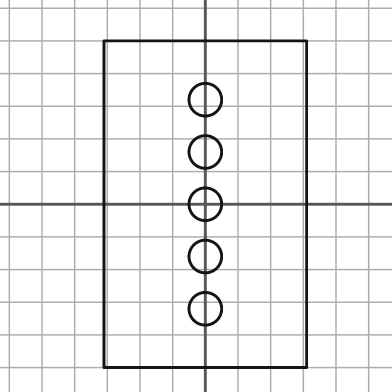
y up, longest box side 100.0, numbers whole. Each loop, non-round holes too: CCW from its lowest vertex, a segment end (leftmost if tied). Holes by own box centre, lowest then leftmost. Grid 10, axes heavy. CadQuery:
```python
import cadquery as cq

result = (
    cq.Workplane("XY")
    .moveTo(-31.0, -50.0)
    .lineTo(31.0, -50.0)
    .lineTo(31.0, 50.0)
    .lineTo(-31.0, 50.0)
    .close()
    .moveTo(0.0, -32.0)
    .circle(5.0)
    .moveTo(0.0, -16.0)
    .circle(5.0)
    .moveTo(0.0, 0.0)
    .circle(5.0)
    .moveTo(0.0, 16.0)
    .circle(5.0)
    .moveTo(0.0, 32.0)
    .circle(5.0)
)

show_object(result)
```